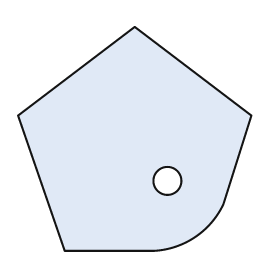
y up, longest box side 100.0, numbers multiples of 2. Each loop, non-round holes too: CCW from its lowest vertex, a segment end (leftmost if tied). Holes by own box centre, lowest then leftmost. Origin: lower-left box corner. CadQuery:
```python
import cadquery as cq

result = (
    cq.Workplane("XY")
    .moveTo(20.0, 0.0)
    .lineTo(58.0, 0.0)
    .threePointArc((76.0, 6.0), (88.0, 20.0))
    .lineTo(100.0, 58.0)
    .lineTo(50.0, 96.0)
    .lineTo(0.0, 58.0)
    .close()
    .moveTo(64.0, 30.0)
    .circle(6.0)
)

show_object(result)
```